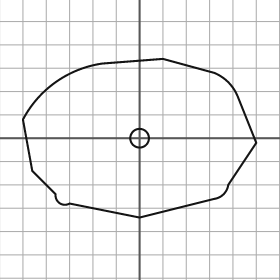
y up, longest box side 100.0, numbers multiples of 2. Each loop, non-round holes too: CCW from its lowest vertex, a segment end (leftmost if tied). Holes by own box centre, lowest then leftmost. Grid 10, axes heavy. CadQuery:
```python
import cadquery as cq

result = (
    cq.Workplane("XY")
    .moveTo(0.0, -34.0)
    .lineTo(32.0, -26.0)
    .threePointArc((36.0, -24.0), (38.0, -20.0))
    .lineTo(50.0, -2.0)
    .lineTo(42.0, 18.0)
    .threePointArc((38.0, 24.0), (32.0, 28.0))
    .lineTo(10.0, 34.0)
    .lineTo(-16.0, 32.0)
    .threePointArc((-36.0, 24.0), (-50.0, 8.0))
    .lineTo(-46.0, -14.0)
    .lineTo(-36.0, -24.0)
    .threePointArc((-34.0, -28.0), (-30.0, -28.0))
    .close()
    .moveTo(0.0, 0.0)
    .circle(4.0)
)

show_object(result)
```